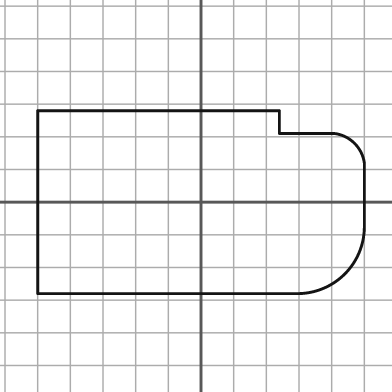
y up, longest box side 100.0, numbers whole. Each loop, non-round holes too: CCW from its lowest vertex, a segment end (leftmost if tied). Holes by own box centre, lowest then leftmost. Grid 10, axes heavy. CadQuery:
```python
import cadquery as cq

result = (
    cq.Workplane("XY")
    .moveTo(-50.0, -28.0)
    .lineTo(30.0, -28.0)
    .threePointArc((44.0, -22.0), (50.0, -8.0))
    .lineTo(50.0, 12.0)
    .threePointArc((47.0, 18.0), (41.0, 21.0))
    .lineTo(24.0, 21.0)
    .lineTo(24.0, 28.0)
    .lineTo(-50.0, 28.0)
    .close()
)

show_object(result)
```